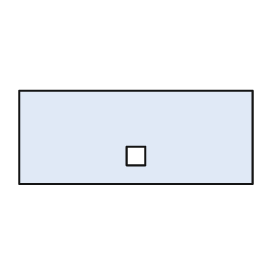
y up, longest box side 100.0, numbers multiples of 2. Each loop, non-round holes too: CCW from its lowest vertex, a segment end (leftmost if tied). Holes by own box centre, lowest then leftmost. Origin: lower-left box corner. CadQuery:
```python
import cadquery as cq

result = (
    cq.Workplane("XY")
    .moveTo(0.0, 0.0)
    .lineTo(100.0, 0.0)
    .lineTo(100.0, 40.0)
    .lineTo(0.0, 40.0)
    .close()
    .moveTo(46.0, 8.0)
    .lineTo(54.0, 8.0)
    .lineTo(54.0, 16.0)
    .lineTo(46.0, 16.0)
    .close()
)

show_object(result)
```